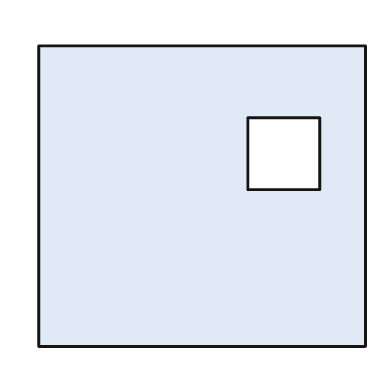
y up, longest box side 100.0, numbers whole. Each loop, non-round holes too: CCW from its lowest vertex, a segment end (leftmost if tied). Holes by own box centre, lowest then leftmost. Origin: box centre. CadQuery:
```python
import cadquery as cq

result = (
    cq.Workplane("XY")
    .moveTo(-50.0, -46.0)
    .lineTo(50.0, -46.0)
    .lineTo(50.0, 46.0)
    .lineTo(-50.0, 46.0)
    .close()
    .moveTo(14.0, 2.0)
    .lineTo(36.0, 2.0)
    .lineTo(36.0, 24.0)
    .lineTo(14.0, 24.0)
    .close()
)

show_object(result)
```